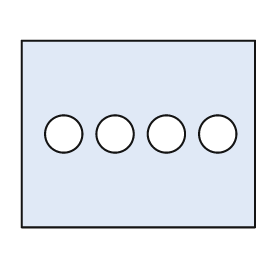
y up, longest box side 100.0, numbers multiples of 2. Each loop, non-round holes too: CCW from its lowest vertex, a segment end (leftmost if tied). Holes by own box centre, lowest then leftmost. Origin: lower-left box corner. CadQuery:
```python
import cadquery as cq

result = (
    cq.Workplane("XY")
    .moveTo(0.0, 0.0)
    .lineTo(100.0, 0.0)
    .lineTo(100.0, 80.0)
    .lineTo(0.0, 80.0)
    .close()
    .moveTo(18.0, 40.0)
    .circle(8.0)
    .moveTo(40.0, 40.0)
    .circle(8.0)
    .moveTo(62.0, 40.0)
    .circle(8.0)
    .moveTo(84.0, 40.0)
    .circle(8.0)
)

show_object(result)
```